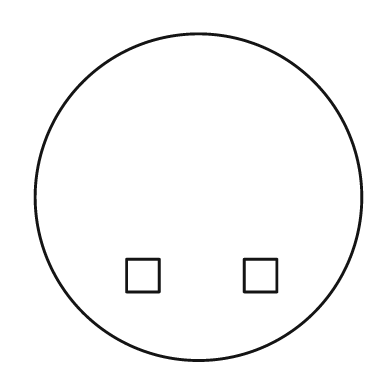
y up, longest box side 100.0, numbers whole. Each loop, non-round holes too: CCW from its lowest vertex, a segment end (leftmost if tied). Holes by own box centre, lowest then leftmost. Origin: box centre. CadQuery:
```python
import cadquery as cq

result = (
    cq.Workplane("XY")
    .moveTo(0.0, 0.0)
    .circle(50.0)
    .moveTo(-22.0, -29.0)
    .lineTo(-12.0, -29.0)
    .lineTo(-12.0, -19.0)
    .lineTo(-22.0, -19.0)
    .close()
    .moveTo(14.0, -29.0)
    .lineTo(24.0, -29.0)
    .lineTo(24.0, -19.0)
    .lineTo(14.0, -19.0)
    .close()
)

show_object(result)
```